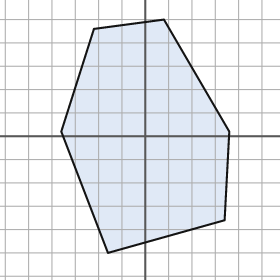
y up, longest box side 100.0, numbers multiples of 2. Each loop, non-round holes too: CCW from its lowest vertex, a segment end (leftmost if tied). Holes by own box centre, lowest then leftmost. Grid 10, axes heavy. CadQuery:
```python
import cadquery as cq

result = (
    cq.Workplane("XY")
    .moveTo(-16.0, -50.0)
    .lineTo(34.0, -36.0)
    .lineTo(36.0, 2.0)
    .lineTo(8.0, 50.0)
    .lineTo(-22.0, 46.0)
    .lineTo(-36.0, 2.0)
    .close()
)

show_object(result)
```